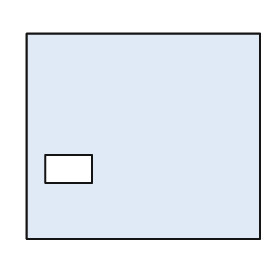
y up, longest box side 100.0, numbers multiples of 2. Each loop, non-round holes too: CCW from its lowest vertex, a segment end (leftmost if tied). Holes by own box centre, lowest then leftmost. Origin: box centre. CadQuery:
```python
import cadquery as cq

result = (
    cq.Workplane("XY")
    .moveTo(-50.0, -44.0)
    .lineTo(50.0, -44.0)
    .lineTo(50.0, 44.0)
    .lineTo(-50.0, 44.0)
    .close()
    .moveTo(-42.0, -20.0)
    .lineTo(-22.0, -20.0)
    .lineTo(-22.0, -8.0)
    .lineTo(-42.0, -8.0)
    .close()
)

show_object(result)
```